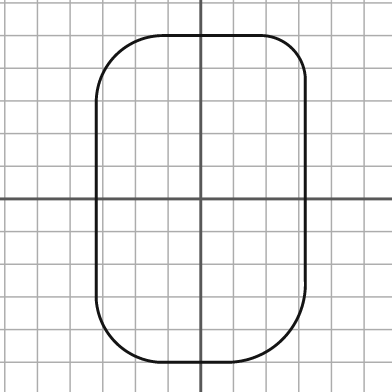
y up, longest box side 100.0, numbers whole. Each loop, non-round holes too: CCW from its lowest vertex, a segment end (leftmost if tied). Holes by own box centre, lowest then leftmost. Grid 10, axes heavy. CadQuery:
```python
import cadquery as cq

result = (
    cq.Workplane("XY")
    .moveTo(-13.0, -50.0)
    .lineTo(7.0, -50.0)
    .threePointArc((25.0, -43.0), (32.0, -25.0))
    .lineTo(32.0, 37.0)
    .threePointArc((28.0, 46.0), (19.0, 50.0))
    .lineTo(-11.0, 50.0)
    .threePointArc((-26.0, 44.0), (-32.0, 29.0))
    .lineTo(-32.0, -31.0)
    .threePointArc((-26.0, -44.0), (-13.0, -50.0))
    .close()
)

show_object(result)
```